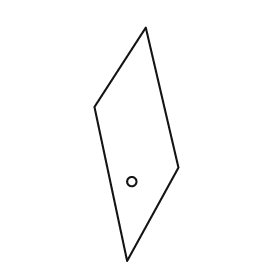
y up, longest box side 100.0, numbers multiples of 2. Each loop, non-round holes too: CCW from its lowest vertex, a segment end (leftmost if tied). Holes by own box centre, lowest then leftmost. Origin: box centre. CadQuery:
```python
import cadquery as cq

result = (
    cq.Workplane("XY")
    .moveTo(-4.0, -50.0)
    .lineTo(18.0, -10.0)
    .lineTo(4.0, 50.0)
    .lineTo(-18.0, 16.0)
    .close()
    .moveTo(-2.0, -16.0)
    .circle(2.0)
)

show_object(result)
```